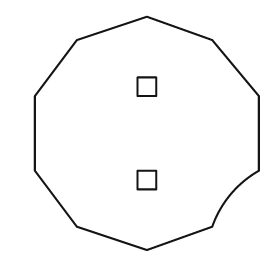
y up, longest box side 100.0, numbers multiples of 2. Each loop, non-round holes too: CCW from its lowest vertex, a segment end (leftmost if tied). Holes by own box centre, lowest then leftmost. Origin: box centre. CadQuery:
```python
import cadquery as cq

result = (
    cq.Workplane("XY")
    .moveTo(0.0, -50.0)
    .lineTo(28.0, -40.0)
    .threePointArc((36.0, -26.0), (48.0, -16.0))
    .lineTo(48.0, 16.0)
    .lineTo(28.0, 40.0)
    .lineTo(0.0, 50.0)
    .lineTo(-30.0, 40.0)
    .lineTo(-48.0, 16.0)
    .lineTo(-48.0, -16.0)
    .lineTo(-30.0, -40.0)
    .close()
    .moveTo(-4.0, -24.0)
    .lineTo(4.0, -24.0)
    .lineTo(4.0, -16.0)
    .lineTo(-4.0, -16.0)
    .close()
    .moveTo(-4.0, 16.0)
    .lineTo(4.0, 16.0)
    .lineTo(4.0, 24.0)
    .lineTo(-4.0, 24.0)
    .close()
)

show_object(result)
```